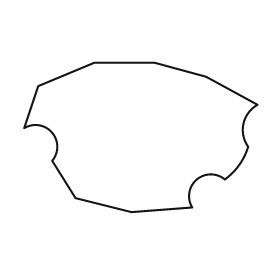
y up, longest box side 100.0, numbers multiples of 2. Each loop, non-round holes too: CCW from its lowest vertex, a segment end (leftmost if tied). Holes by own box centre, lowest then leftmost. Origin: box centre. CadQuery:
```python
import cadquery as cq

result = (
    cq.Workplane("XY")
    .moveTo(-4.0, -32.0)
    .lineTo(22.0, -30.0)
    .threePointArc((24.0, -18.0), (36.0, -18.0))
    .threePointArc((42.0, -12.0), (46.0, -4.0))
    .threePointArc((44.0, 6.0), (50.0, 14.0))
    .lineTo(28.0, 26.0)
    .lineTo(6.0, 32.0)
    .lineTo(-20.0, 32.0)
    .lineTo(-44.0, 22.0)
    .lineTo(-50.0, 4.0)
    .threePointArc((-38.0, 2.0), (-38.0, -10.0))
    .lineTo(-28.0, -26.0)
    .close()
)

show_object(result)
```